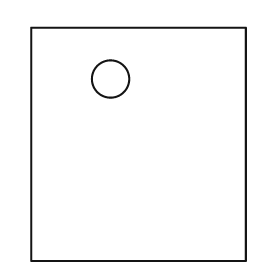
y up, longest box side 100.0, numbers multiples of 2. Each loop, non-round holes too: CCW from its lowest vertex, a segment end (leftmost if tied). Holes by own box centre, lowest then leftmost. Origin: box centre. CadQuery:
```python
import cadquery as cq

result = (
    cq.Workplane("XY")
    .moveTo(-46.0, -50.0)
    .lineTo(46.0, -50.0)
    .lineTo(46.0, 50.0)
    .lineTo(-46.0, 50.0)
    .close()
    .moveTo(-12.0, 28.0)
    .circle(8.0)
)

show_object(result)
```